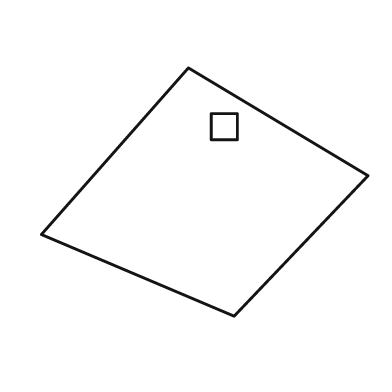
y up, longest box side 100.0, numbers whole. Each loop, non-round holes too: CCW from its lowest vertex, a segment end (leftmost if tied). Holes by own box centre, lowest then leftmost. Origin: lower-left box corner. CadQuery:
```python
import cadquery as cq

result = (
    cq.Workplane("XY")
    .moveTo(59.0, 0.0)
    .lineTo(100.0, 43.0)
    .lineTo(45.0, 76.0)
    .lineTo(0.0, 25.0)
    .close()
    .moveTo(52.0, 54.0)
    .lineTo(60.0, 54.0)
    .lineTo(60.0, 62.0)
    .lineTo(52.0, 62.0)
    .close()
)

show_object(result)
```